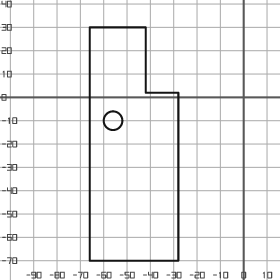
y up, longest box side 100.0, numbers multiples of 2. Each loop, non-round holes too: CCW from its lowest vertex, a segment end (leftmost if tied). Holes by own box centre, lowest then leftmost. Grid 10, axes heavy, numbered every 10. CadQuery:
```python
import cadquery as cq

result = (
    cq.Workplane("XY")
    .moveTo(-66.0, -70.0)
    .lineTo(-28.0, -70.0)
    .lineTo(-28.0, 2.0)
    .lineTo(-42.0, 2.0)
    .lineTo(-42.0, 30.0)
    .lineTo(-66.0, 30.0)
    .close()
    .moveTo(-56.0, -10.0)
    .circle(4.0)
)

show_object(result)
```